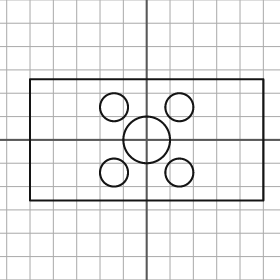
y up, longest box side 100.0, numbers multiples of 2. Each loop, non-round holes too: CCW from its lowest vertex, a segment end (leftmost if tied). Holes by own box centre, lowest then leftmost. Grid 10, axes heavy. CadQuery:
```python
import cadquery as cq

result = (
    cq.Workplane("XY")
    .moveTo(-50.0, -26.0)
    .lineTo(50.0, -26.0)
    .lineTo(50.0, 26.0)
    .lineTo(-50.0, 26.0)
    .close()
    .moveTo(-14.0, -14.0)
    .circle(6.0)
    .moveTo(14.0, -14.0)
    .circle(6.0)
    .moveTo(0.0, 0.0)
    .circle(10.0)
    .moveTo(-14.0, 14.0)
    .circle(6.0)
    .moveTo(14.0, 14.0)
    .circle(6.0)
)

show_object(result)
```